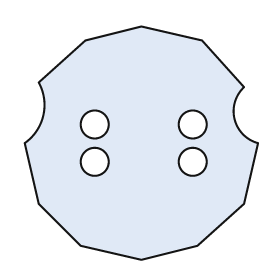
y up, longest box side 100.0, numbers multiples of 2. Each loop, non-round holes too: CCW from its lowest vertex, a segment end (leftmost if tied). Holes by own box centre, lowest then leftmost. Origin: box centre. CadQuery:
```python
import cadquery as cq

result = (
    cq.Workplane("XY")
    .moveTo(0.0, -50.0)
    .lineTo(24.0, -44.0)
    .lineTo(44.0, -26.0)
    .lineTo(50.0, 0.0)
    .threePointArc((40.0, 10.0), (44.0, 24.0))
    .lineTo(26.0, 44.0)
    .lineTo(0.0, 50.0)
    .lineTo(-24.0, 44.0)
    .lineTo(-44.0, 26.0)
    .threePointArc((-42.0, 12.0), (-50.0, 0.0))
    .lineTo(-44.0, -26.0)
    .lineTo(-26.0, -44.0)
    .close()
    .moveTo(-20.0, -8.0)
    .circle(6.0)
    .moveTo(22.0, -8.0)
    .circle(6.0)
    .moveTo(-20.0, 8.0)
    .circle(6.0)
    .moveTo(22.0, 8.0)
    .circle(6.0)
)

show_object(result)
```